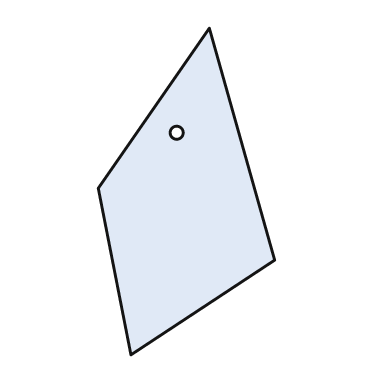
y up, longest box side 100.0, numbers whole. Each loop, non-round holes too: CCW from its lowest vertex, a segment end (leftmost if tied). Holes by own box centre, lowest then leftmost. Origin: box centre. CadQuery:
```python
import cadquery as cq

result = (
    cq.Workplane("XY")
    .moveTo(-17.0, -50.0)
    .lineTo(27.0, -21.0)
    .lineTo(7.0, 50.0)
    .lineTo(-27.0, 1.0)
    .close()
    .moveTo(-3.0, 18.0)
    .circle(2.0)
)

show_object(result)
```